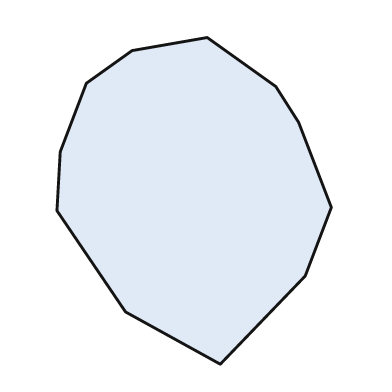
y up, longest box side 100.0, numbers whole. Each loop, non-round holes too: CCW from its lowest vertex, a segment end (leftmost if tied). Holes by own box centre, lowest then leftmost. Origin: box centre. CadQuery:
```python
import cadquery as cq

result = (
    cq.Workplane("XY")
    .moveTo(8.0, -50.0)
    .lineTo(34.0, -23.0)
    .lineTo(42.0, -2.0)
    .lineTo(32.0, 24.0)
    .lineTo(25.0, 35.0)
    .lineTo(4.0, 50.0)
    .lineTo(-19.0, 46.0)
    .lineTo(-33.0, 36.0)
    .lineTo(-41.0, 15.0)
    .lineTo(-42.0, -3.0)
    .lineTo(-21.0, -34.0)
    .close()
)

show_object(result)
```